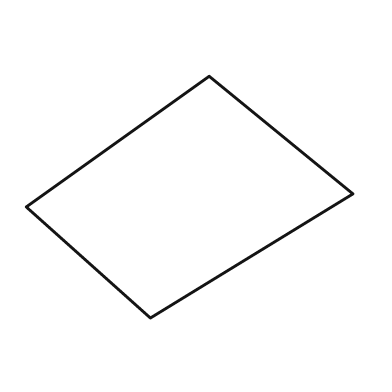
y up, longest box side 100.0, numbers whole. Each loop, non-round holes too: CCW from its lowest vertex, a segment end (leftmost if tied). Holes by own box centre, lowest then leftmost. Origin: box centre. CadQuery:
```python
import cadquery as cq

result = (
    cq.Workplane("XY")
    .moveTo(-12.0, -37.0)
    .lineTo(50.0, 1.0)
    .lineTo(6.0, 37.0)
    .lineTo(-50.0, -3.0)
    .close()
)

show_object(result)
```